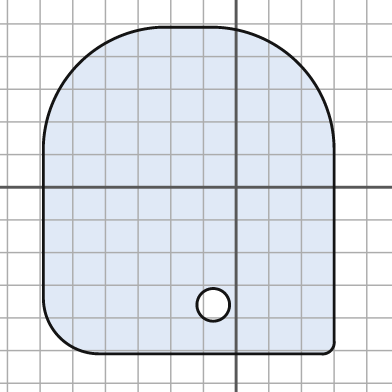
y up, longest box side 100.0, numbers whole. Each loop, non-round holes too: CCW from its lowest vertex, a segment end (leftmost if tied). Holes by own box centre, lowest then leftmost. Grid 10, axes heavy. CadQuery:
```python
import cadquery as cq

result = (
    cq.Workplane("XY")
    .moveTo(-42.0, -51.0)
    .lineTo(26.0, -51.0)
    .threePointArc((29.0, -50.0), (30.0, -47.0))
    .lineTo(30.0, 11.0)
    .threePointArc((19.0, 38.0), (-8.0, 49.0))
    .lineTo(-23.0, 49.0)
    .threePointArc((-48.0, 38.0), (-59.0, 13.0))
    .lineTo(-59.0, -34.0)
    .threePointArc((-54.0, -46.0), (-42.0, -51.0))
    .close()
    .moveTo(-7.0, -36.0)
    .circle(5.0)
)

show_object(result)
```